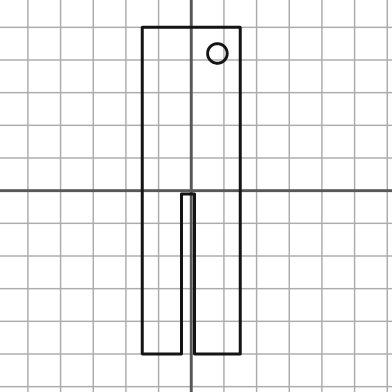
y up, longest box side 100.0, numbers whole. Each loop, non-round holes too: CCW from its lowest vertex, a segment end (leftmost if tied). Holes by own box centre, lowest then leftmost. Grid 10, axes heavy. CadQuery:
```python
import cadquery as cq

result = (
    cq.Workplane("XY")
    .moveTo(-15.0, -50.0)
    .lineTo(-3.0, -50.0)
    .lineTo(-3.0, -1.0)
    .lineTo(1.0, -1.0)
    .lineTo(1.0, -50.0)
    .lineTo(15.0, -50.0)
    .lineTo(15.0, 50.0)
    .lineTo(-15.0, 50.0)
    .close()
    .moveTo(8.0, 42.0)
    .circle(3.0)
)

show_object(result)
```